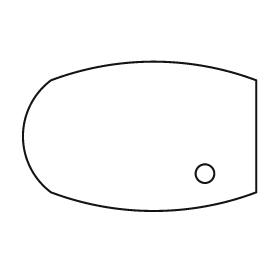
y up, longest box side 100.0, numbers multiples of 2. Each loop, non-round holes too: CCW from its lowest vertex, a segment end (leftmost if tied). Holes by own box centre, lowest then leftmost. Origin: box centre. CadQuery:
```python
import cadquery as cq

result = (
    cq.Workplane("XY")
    .moveTo(-38.0, -24.0)
    .threePointArc((6.0, -32.0), (50.0, -24.0))
    .lineTo(50.0, 24.0)
    .threePointArc((6.0, 32.0), (-38.0, 24.0))
    .threePointArc((-50.0, 0.0), (-38.0, -24.0))
    .close()
    .moveTo(28.0, -16.0)
    .circle(4.0)
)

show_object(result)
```